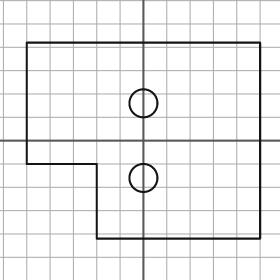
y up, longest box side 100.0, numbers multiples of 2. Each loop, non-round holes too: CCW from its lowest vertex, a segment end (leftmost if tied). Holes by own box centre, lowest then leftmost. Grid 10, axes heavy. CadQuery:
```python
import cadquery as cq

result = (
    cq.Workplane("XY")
    .moveTo(-20.0, -42.0)
    .lineTo(50.0, -42.0)
    .lineTo(50.0, 42.0)
    .lineTo(-50.0, 42.0)
    .lineTo(-50.0, -10.0)
    .lineTo(-20.0, -10.0)
    .close()
    .moveTo(0.0, -16.0)
    .circle(6.0)
    .moveTo(0.0, 16.0)
    .circle(6.0)
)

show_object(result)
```